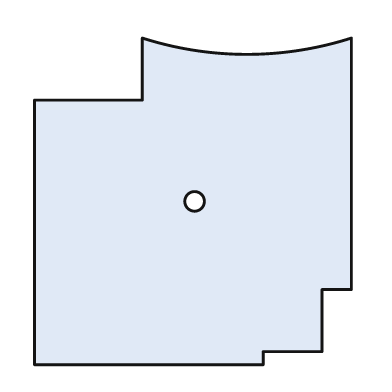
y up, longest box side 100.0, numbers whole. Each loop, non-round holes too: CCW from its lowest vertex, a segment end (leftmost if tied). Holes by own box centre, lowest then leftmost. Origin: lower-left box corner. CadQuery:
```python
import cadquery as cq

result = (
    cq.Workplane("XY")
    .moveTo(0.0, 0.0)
    .lineTo(70.0, 0.0)
    .lineTo(70.0, 4.0)
    .lineTo(88.0, 4.0)
    .lineTo(88.0, 23.0)
    .lineTo(97.0, 23.0)
    .lineTo(97.0, 100.0)
    .threePointArc((65.0, 95.0), (33.0, 100.0))
    .lineTo(33.0, 81.0)
    .lineTo(0.0, 81.0)
    .close()
    .moveTo(49.0, 50.0)
    .circle(3.0)
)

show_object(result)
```